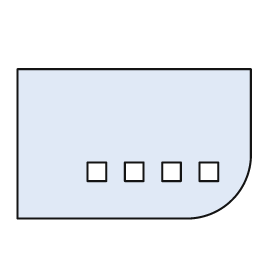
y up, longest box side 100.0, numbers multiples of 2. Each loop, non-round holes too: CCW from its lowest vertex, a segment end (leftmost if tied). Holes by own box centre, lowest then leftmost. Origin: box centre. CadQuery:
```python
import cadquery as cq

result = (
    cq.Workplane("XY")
    .moveTo(-50.0, -32.0)
    .lineTo(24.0, -32.0)
    .threePointArc((42.0, -24.0), (50.0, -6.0))
    .lineTo(50.0, 32.0)
    .lineTo(-50.0, 32.0)
    .close()
    .moveTo(-20.0, -16.0)
    .lineTo(-12.0, -16.0)
    .lineTo(-12.0, -8.0)
    .lineTo(-20.0, -8.0)
    .close()
    .moveTo(-4.0, -16.0)
    .lineTo(4.0, -16.0)
    .lineTo(4.0, -8.0)
    .lineTo(-4.0, -8.0)
    .close()
    .moveTo(12.0, -16.0)
    .lineTo(20.0, -16.0)
    .lineTo(20.0, -8.0)
    .lineTo(12.0, -8.0)
    .close()
    .moveTo(28.0, -16.0)
    .lineTo(36.0, -16.0)
    .lineTo(36.0, -8.0)
    .lineTo(28.0, -8.0)
    .close()
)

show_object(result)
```